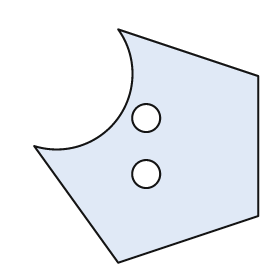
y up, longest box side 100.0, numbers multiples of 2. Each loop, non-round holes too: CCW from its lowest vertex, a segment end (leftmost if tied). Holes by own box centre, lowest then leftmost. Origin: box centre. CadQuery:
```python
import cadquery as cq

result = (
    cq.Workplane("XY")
    .moveTo(-12.0, -50.0)
    .lineTo(48.0, -30.0)
    .lineTo(48.0, 30.0)
    .lineTo(-12.0, 50.0)
    .threePointArc((-12.0, 12.0), (-48.0, 0.0))
    .close()
    .moveTo(0.0, -12.0)
    .circle(6.0)
    .moveTo(0.0, 12.0)
    .circle(6.0)
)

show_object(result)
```